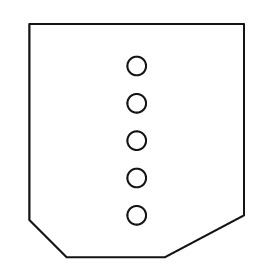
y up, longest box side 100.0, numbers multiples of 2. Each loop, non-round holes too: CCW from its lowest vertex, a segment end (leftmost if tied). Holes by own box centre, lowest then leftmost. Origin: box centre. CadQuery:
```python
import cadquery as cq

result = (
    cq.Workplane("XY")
    .moveTo(-30.0, -50.0)
    .lineTo(12.0, -50.0)
    .lineTo(46.0, -32.0)
    .lineTo(46.0, 50.0)
    .lineTo(-46.0, 50.0)
    .lineTo(-46.0, -34.0)
    .close()
    .moveTo(0.0, -32.0)
    .circle(4.0)
    .moveTo(0.0, -16.0)
    .circle(4.0)
    .moveTo(0.0, 0.0)
    .circle(4.0)
    .moveTo(0.0, 16.0)
    .circle(4.0)
    .moveTo(0.0, 32.0)
    .circle(4.0)
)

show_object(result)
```